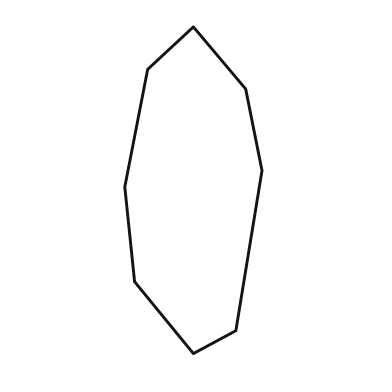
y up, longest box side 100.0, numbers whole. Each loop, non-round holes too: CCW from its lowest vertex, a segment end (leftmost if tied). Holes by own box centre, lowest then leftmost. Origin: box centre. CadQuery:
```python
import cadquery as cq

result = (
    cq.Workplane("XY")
    .moveTo(0.0, -50.0)
    .lineTo(13.0, -43.0)
    .lineTo(21.0, 6.0)
    .lineTo(16.0, 31.0)
    .lineTo(0.0, 50.0)
    .lineTo(-14.0, 37.0)
    .lineTo(-21.0, 1.0)
    .lineTo(-18.0, -28.0)
    .close()
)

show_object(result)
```